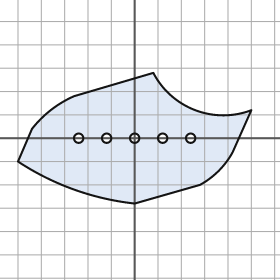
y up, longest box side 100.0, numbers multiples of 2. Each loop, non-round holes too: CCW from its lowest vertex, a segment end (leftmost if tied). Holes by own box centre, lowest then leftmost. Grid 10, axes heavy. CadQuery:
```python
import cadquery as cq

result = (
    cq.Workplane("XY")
    .moveTo(0.0, -28.0)
    .lineTo(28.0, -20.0)
    .threePointArc((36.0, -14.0), (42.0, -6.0))
    .lineTo(50.0, 12.0)
    .threePointArc((26.0, 12.0), (8.0, 28.0))
    .lineTo(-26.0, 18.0)
    .threePointArc((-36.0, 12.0), (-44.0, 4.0))
    .lineTo(-50.0, -10.0)
    .threePointArc((-26.0, -22.0), (0.0, -28.0))
    .close()
    .moveTo(-24.0, 0.0)
    .circle(2.0)
    .moveTo(-12.0, 0.0)
    .circle(2.0)
    .moveTo(0.0, 0.0)
    .circle(2.0)
    .moveTo(12.0, 0.0)
    .circle(2.0)
    .moveTo(24.0, 0.0)
    .circle(2.0)
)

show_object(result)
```